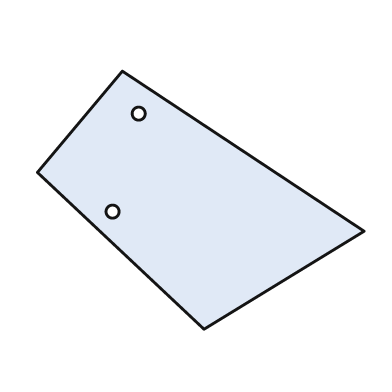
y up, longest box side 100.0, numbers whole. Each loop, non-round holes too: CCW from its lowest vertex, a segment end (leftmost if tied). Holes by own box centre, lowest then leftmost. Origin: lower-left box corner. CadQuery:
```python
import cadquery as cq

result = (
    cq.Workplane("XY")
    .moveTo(51.0, 0.0)
    .lineTo(100.0, 30.0)
    .lineTo(26.0, 79.0)
    .lineTo(0.0, 48.0)
    .close()
    .moveTo(23.0, 36.0)
    .circle(2.0)
    .moveTo(31.0, 66.0)
    .circle(2.0)
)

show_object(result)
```